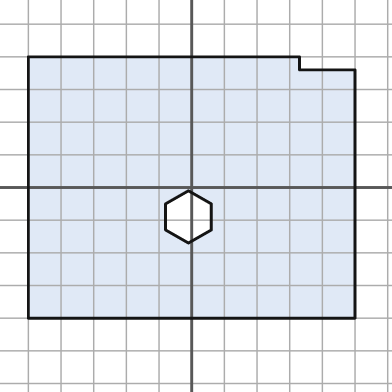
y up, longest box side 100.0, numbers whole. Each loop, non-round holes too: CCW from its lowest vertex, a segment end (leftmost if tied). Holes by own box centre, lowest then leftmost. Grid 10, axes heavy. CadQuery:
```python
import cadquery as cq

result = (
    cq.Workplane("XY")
    .moveTo(-50.0, -40.0)
    .lineTo(50.0, -40.0)
    .lineTo(50.0, 36.0)
    .lineTo(33.0, 36.0)
    .lineTo(33.0, 40.0)
    .lineTo(-50.0, 40.0)
    .close()
    .moveTo(-1.0, -17.0)
    .lineTo(6.0, -13.0)
    .lineTo(6.0, -5.0)
    .lineTo(-1.0, -1.0)
    .lineTo(-8.0, -5.0)
    .lineTo(-8.0, -13.0)
    .close()
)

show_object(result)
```